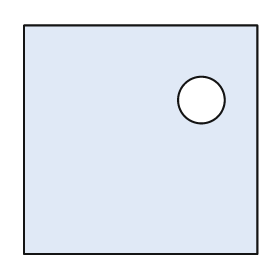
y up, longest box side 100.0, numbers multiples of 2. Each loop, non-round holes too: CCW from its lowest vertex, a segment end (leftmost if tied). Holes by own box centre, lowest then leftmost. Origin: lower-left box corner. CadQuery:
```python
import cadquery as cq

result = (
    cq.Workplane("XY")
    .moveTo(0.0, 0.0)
    .lineTo(100.0, 0.0)
    .lineTo(100.0, 98.0)
    .lineTo(0.0, 98.0)
    .close()
    .moveTo(76.0, 66.0)
    .circle(10.0)
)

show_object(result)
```